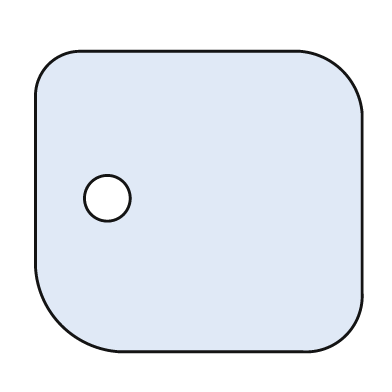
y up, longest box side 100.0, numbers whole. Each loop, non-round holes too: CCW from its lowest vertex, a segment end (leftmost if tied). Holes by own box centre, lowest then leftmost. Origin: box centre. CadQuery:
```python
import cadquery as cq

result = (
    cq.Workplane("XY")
    .moveTo(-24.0, -46.0)
    .lineTo(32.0, -46.0)
    .threePointArc((45.0, -41.0), (50.0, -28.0))
    .lineTo(50.0, 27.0)
    .threePointArc((44.0, 40.0), (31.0, 46.0))
    .lineTo(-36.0, 46.0)
    .threePointArc((-46.0, 42.0), (-50.0, 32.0))
    .lineTo(-50.0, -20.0)
    .threePointArc((-42.0, -38.0), (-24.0, -46.0))
    .close()
    .moveTo(-28.0, 1.0)
    .circle(7.0)
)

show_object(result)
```